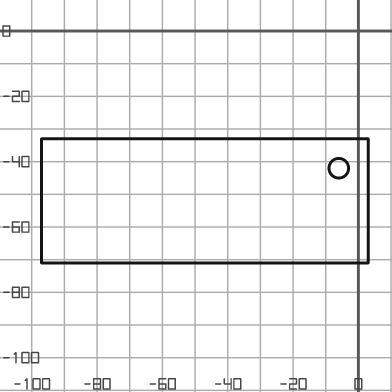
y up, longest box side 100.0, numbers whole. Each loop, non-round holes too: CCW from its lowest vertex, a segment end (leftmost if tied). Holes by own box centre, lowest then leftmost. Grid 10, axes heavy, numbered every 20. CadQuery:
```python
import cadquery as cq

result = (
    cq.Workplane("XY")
    .moveTo(-97.0, -71.0)
    .lineTo(3.0, -71.0)
    .lineTo(3.0, -33.0)
    .lineTo(-97.0, -33.0)
    .close()
    .moveTo(-6.0, -42.0)
    .circle(3.0)
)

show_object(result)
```